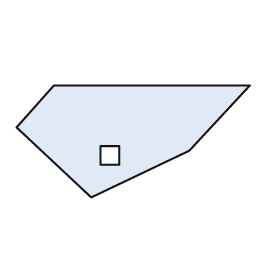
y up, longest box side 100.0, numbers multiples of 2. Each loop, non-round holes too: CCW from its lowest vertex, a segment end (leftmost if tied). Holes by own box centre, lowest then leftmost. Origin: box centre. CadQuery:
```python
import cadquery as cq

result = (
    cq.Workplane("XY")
    .moveTo(-18.0, -24.0)
    .lineTo(24.0, -4.0)
    .lineTo(50.0, 24.0)
    .lineTo(-34.0, 24.0)
    .lineTo(-50.0, 6.0)
    .close()
    .moveTo(-14.0, -10.0)
    .lineTo(-6.0, -10.0)
    .lineTo(-6.0, -2.0)
    .lineTo(-14.0, -2.0)
    .close()
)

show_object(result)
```